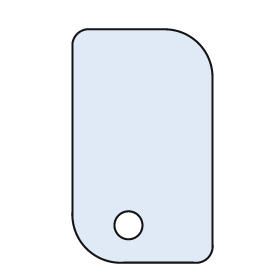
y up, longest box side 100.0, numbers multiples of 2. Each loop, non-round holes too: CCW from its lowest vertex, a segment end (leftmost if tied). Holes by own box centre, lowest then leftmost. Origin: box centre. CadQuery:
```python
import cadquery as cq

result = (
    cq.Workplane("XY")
    .moveTo(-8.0, -50.0)
    .lineTo(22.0, -50.0)
    .threePointArc((28.0, -48.0), (30.0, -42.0))
    .lineTo(30.0, 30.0)
    .threePointArc((24.0, 44.0), (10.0, 50.0))
    .lineTo(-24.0, 50.0)
    .threePointArc((-28.0, 48.0), (-30.0, 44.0))
    .lineTo(-30.0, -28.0)
    .threePointArc((-24.0, -44.0), (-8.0, -50.0))
    .close()
    .moveTo(-6.0, -34.0)
    .circle(6.0)
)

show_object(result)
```